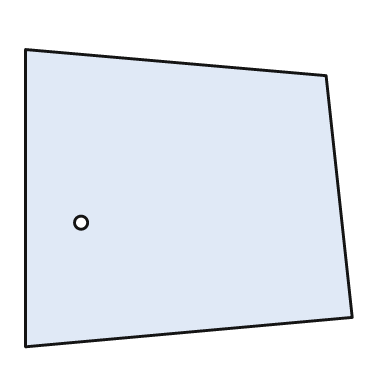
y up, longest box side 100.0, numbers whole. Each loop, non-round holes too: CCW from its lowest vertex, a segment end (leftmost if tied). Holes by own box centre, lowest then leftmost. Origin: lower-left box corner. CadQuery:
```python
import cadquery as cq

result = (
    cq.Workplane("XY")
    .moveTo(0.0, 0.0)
    .lineTo(100.0, 9.0)
    .lineTo(92.0, 83.0)
    .lineTo(0.0, 91.0)
    .close()
    .moveTo(17.0, 38.0)
    .circle(2.0)
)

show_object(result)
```